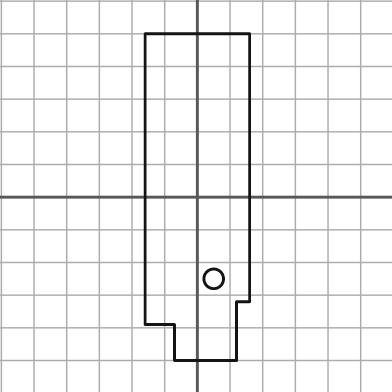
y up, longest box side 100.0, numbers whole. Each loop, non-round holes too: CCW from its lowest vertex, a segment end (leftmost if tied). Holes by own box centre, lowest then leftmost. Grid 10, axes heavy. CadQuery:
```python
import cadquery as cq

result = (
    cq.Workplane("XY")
    .moveTo(-7.0, -50.0)
    .lineTo(12.0, -50.0)
    .lineTo(12.0, -32.0)
    .lineTo(16.0, -32.0)
    .lineTo(16.0, 50.0)
    .lineTo(-16.0, 50.0)
    .lineTo(-16.0, -39.0)
    .lineTo(-7.0, -39.0)
    .close()
    .moveTo(5.0, -25.0)
    .circle(3.0)
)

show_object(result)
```